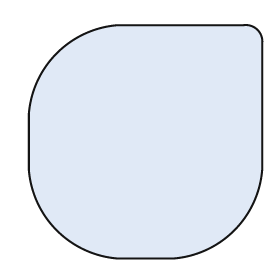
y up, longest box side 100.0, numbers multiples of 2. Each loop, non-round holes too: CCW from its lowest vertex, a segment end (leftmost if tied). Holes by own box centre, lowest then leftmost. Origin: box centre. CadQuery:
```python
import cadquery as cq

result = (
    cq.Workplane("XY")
    .moveTo(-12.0, -50.0)
    .lineTo(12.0, -50.0)
    .threePointArc((38.0, -38.0), (50.0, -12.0))
    .lineTo(50.0, 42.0)
    .threePointArc((48.0, 48.0), (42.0, 50.0))
    .lineTo(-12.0, 50.0)
    .threePointArc((-38.0, 38.0), (-50.0, 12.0))
    .lineTo(-50.0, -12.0)
    .threePointArc((-38.0, -38.0), (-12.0, -50.0))
    .close()
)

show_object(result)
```